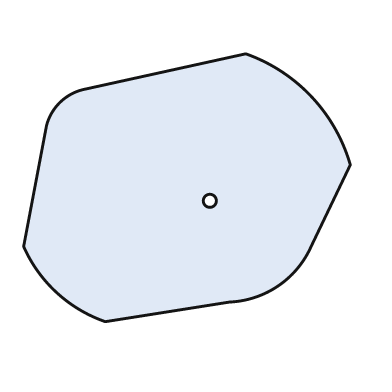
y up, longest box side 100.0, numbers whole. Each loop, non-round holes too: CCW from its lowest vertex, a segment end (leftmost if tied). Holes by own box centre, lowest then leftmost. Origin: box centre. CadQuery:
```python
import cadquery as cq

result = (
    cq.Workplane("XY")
    .moveTo(-25.0, -41.0)
    .lineTo(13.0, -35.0)
    .threePointArc((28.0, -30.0), (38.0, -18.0))
    .lineTo(50.0, 7.0)
    .threePointArc((38.0, 28.0), (18.0, 41.0))
    .lineTo(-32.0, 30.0)
    .threePointArc((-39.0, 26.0), (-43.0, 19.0))
    .lineTo(-50.0, -18.0)
    .threePointArc((-40.0, -32.0), (-25.0, -41.0))
    .close()
    .moveTo(7.0, -4.0)
    .circle(2.0)
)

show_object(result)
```